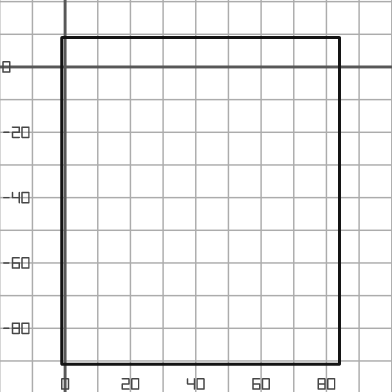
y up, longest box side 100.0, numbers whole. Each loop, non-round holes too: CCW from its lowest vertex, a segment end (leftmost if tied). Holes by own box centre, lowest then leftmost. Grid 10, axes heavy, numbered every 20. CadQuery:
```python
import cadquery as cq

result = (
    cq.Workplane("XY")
    .moveTo(-1.0, -91.0)
    .lineTo(84.0, -91.0)
    .lineTo(84.0, 9.0)
    .lineTo(-1.0, 9.0)
    .close()
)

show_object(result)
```